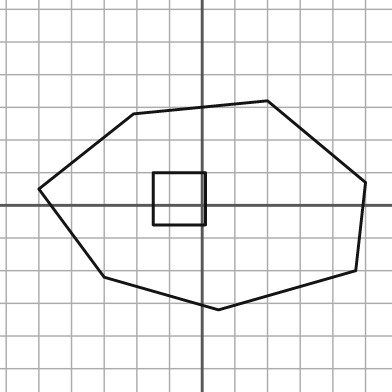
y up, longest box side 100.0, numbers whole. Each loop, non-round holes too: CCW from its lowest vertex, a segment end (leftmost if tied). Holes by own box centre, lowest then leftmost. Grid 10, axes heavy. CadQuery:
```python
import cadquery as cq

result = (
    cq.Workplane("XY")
    .moveTo(5.0, -32.0)
    .lineTo(47.0, -20.0)
    .lineTo(50.0, 7.0)
    .lineTo(20.0, 32.0)
    .lineTo(-21.0, 28.0)
    .lineTo(-50.0, 5.0)
    .lineTo(-30.0, -22.0)
    .close()
    .moveTo(-15.0, -6.0)
    .lineTo(1.0, -6.0)
    .lineTo(1.0, 10.0)
    .lineTo(-15.0, 10.0)
    .close()
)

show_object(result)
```